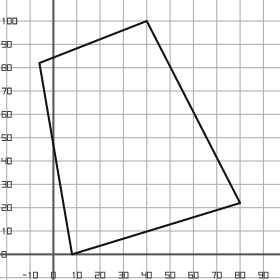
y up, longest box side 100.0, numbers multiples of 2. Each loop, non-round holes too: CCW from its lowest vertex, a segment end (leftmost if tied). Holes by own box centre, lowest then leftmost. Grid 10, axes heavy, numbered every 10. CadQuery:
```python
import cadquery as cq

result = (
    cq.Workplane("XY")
    .moveTo(8.0, 0.0)
    .lineTo(80.0, 22.0)
    .lineTo(40.0, 100.0)
    .lineTo(-6.0, 82.0)
    .close()
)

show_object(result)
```